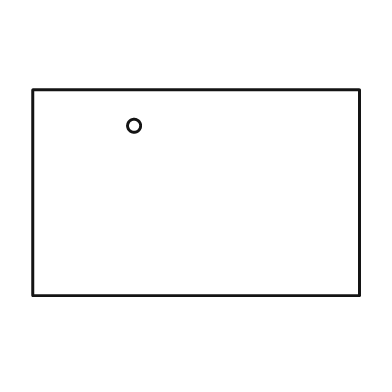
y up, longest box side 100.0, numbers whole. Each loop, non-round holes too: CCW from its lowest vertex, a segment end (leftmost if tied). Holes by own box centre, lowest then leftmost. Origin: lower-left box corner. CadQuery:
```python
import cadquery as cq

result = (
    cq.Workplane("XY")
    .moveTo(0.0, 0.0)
    .lineTo(100.0, 0.0)
    .lineTo(100.0, 63.0)
    .lineTo(0.0, 63.0)
    .close()
    .moveTo(31.0, 52.0)
    .circle(2.0)
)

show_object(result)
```